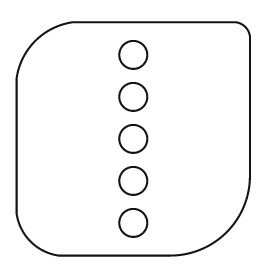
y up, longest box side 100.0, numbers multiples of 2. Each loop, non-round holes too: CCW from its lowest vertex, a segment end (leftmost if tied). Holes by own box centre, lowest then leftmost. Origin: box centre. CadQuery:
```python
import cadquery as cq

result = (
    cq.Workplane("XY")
    .moveTo(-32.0, -50.0)
    .lineTo(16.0, -50.0)
    .threePointArc((40.0, -40.0), (50.0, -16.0))
    .lineTo(50.0, 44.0)
    .threePointArc((48.0, 48.0), (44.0, 50.0))
    .lineTo(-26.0, 50.0)
    .threePointArc((-42.0, 42.0), (-50.0, 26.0))
    .lineTo(-50.0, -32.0)
    .threePointArc((-44.0, -44.0), (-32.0, -50.0))
    .close()
    .moveTo(0.0, -36.0)
    .circle(6.0)
    .moveTo(0.0, -18.0)
    .circle(6.0)
    .moveTo(0.0, 0.0)
    .circle(6.0)
    .moveTo(0.0, 18.0)
    .circle(6.0)
    .moveTo(0.0, 36.0)
    .circle(6.0)
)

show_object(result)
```